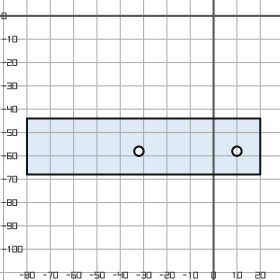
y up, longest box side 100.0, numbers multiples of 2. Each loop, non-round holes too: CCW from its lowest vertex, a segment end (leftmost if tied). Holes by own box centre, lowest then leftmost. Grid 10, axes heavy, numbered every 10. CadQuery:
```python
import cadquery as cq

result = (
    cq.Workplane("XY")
    .moveTo(-80.0, -68.0)
    .lineTo(20.0, -68.0)
    .lineTo(20.0, -44.0)
    .lineTo(-80.0, -44.0)
    .close()
    .moveTo(-32.0, -58.0)
    .circle(2.0)
    .moveTo(10.0, -58.0)
    .circle(2.0)
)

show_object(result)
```